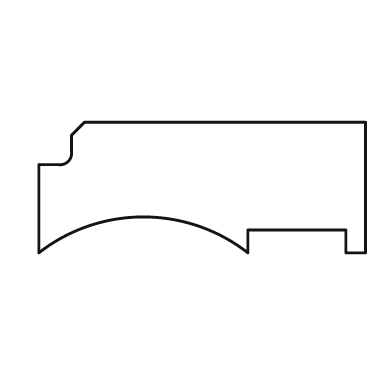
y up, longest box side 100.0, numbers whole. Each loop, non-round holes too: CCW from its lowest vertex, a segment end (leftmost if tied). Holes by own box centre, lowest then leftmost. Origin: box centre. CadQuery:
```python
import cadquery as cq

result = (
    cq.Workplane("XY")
    .moveTo(-50.0, -20.0)
    .threePointArc((-18.0, -9.0), (14.0, -20.0))
    .lineTo(14.0, -13.0)
    .lineTo(44.0, -13.0)
    .lineTo(44.0, -20.0)
    .lineTo(50.0, -20.0)
    .lineTo(50.0, 20.0)
    .lineTo(-36.0, 20.0)
    .lineTo(-40.0, 16.0)
    .lineTo(-40.0, 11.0)
    .threePointArc((-41.0, 8.0), (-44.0, 7.0))
    .lineTo(-50.0, 7.0)
    .close()
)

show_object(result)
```